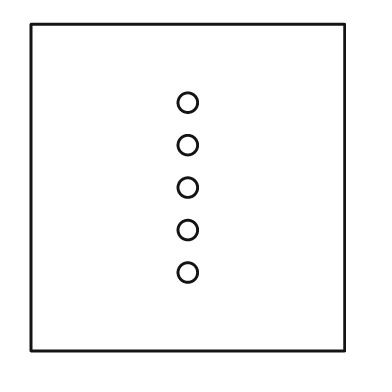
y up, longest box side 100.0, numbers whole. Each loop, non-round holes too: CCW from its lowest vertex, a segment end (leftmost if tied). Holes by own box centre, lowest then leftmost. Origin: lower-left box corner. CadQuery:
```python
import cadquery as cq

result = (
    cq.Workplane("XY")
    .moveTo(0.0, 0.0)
    .lineTo(96.0, 0.0)
    .lineTo(96.0, 100.0)
    .lineTo(0.0, 100.0)
    .close()
    .moveTo(48.0, 24.0)
    .circle(3.0)
    .moveTo(48.0, 37.0)
    .circle(3.0)
    .moveTo(48.0, 50.0)
    .circle(3.0)
    .moveTo(48.0, 63.0)
    .circle(3.0)
    .moveTo(48.0, 76.0)
    .circle(3.0)
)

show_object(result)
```